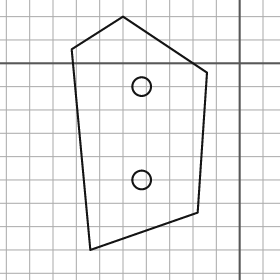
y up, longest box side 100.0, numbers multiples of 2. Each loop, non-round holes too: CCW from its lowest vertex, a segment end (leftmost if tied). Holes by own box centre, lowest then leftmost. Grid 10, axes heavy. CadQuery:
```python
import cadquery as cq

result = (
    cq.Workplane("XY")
    .moveTo(-64.0, -80.0)
    .lineTo(-18.0, -64.0)
    .lineTo(-14.0, -4.0)
    .lineTo(-50.0, 20.0)
    .lineTo(-72.0, 6.0)
    .close()
    .moveTo(-42.0, -50.0)
    .circle(4.0)
    .moveTo(-42.0, -10.0)
    .circle(4.0)
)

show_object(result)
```